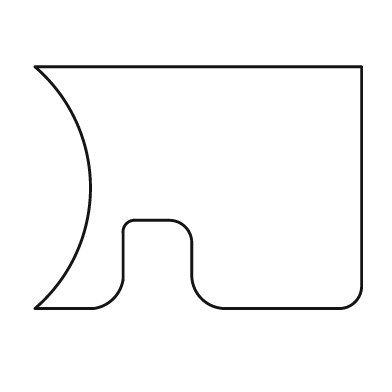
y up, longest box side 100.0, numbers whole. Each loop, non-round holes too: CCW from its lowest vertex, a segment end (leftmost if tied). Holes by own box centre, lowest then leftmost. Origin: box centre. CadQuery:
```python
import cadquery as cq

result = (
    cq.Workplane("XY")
    .moveTo(-50.0, -37.0)
    .lineTo(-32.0, -37.0)
    .threePointArc((-26.0, -34.0), (-23.0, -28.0))
    .lineTo(-23.0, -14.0)
    .threePointArc((-22.0, -11.0), (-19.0, -10.0))
    .lineTo(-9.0, -10.0)
    .threePointArc((-4.0, -12.0), (-2.0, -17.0))
    .lineTo(-2.0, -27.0)
    .threePointArc((1.0, -34.0), (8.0, -37.0))
    .lineTo(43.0, -37.0)
    .threePointArc((48.0, -35.0), (50.0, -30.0))
    .lineTo(50.0, 37.0)
    .lineTo(-50.0, 37.0)
    .threePointArc((-33.0, 0.0), (-50.0, -37.0))
    .close()
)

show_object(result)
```